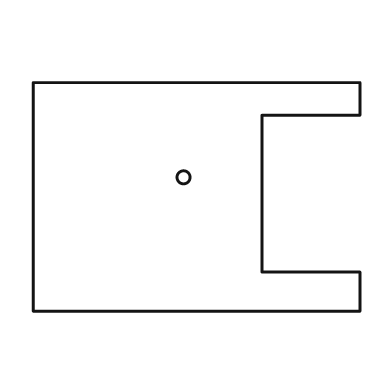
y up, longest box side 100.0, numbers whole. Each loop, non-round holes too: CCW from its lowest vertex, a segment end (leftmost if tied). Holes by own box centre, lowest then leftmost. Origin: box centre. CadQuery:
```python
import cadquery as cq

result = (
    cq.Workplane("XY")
    .moveTo(-50.0, -35.0)
    .lineTo(50.0, -35.0)
    .lineTo(50.0, -23.0)
    .lineTo(20.0, -23.0)
    .lineTo(20.0, 25.0)
    .lineTo(50.0, 25.0)
    .lineTo(50.0, 35.0)
    .lineTo(-50.0, 35.0)
    .close()
    .moveTo(-4.0, 6.0)
    .circle(2.0)
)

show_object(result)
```